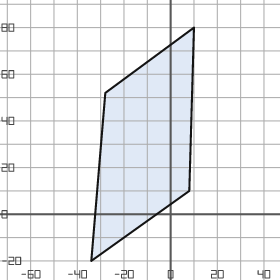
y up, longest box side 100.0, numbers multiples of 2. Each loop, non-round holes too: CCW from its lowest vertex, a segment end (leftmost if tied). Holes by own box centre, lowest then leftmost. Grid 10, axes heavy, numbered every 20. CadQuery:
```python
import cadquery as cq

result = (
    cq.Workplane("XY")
    .moveTo(-34.0, -20.0)
    .lineTo(8.0, 10.0)
    .lineTo(10.0, 80.0)
    .lineTo(-28.0, 52.0)
    .close()
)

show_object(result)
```